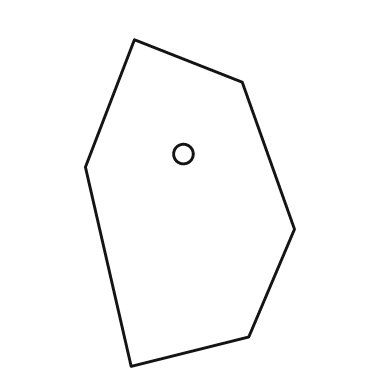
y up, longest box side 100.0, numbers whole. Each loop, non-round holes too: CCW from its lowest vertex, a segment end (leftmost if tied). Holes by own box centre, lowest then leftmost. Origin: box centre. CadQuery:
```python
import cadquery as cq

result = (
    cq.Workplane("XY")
    .moveTo(-18.0, -50.0)
    .lineTo(18.0, -41.0)
    .lineTo(32.0, -8.0)
    .lineTo(16.0, 37.0)
    .lineTo(-17.0, 50.0)
    .lineTo(-32.0, 11.0)
    .close()
    .moveTo(-2.0, 15.0)
    .circle(3.0)
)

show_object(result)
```